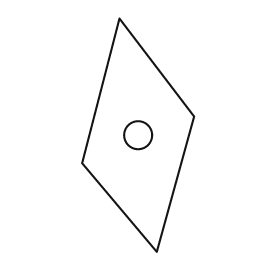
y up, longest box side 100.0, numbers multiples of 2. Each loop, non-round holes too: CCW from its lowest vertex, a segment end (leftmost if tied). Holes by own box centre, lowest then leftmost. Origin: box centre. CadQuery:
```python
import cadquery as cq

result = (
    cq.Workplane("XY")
    .moveTo(8.0, -50.0)
    .lineTo(24.0, 8.0)
    .lineTo(-8.0, 50.0)
    .lineTo(-24.0, -12.0)
    .close()
    .moveTo(0.0, 0.0)
    .circle(6.0)
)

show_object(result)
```